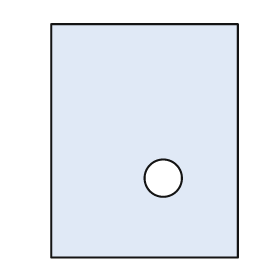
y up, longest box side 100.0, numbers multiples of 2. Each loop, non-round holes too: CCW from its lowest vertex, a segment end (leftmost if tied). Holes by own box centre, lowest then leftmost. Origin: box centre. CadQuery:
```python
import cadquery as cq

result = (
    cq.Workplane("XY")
    .moveTo(-40.0, -50.0)
    .lineTo(40.0, -50.0)
    .lineTo(40.0, 50.0)
    .lineTo(-40.0, 50.0)
    .close()
    .moveTo(8.0, -16.0)
    .circle(8.0)
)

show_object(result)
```